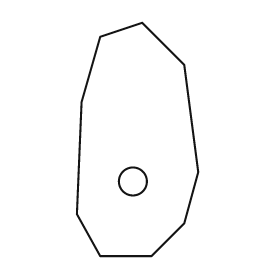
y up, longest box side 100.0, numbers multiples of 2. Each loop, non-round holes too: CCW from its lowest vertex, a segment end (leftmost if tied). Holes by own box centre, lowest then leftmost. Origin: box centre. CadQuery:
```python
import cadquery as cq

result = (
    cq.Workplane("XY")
    .moveTo(-16.0, -50.0)
    .lineTo(6.0, -50.0)
    .lineTo(20.0, -36.0)
    .lineTo(26.0, -14.0)
    .lineTo(20.0, 32.0)
    .lineTo(2.0, 50.0)
    .lineTo(-16.0, 44.0)
    .lineTo(-24.0, 16.0)
    .lineTo(-26.0, -32.0)
    .close()
    .moveTo(-2.0, -18.0)
    .circle(6.0)
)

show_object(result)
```